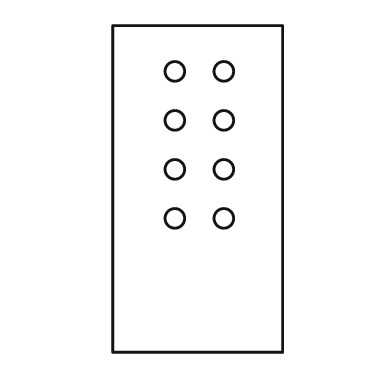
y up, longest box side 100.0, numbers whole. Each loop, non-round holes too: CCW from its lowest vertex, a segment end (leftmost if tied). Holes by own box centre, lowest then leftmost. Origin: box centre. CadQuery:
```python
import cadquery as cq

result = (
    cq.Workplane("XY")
    .moveTo(-26.0, -50.0)
    .lineTo(26.0, -50.0)
    .lineTo(26.0, 50.0)
    .lineTo(-26.0, 50.0)
    .close()
    .moveTo(-7.0, -9.0)
    .circle(3.0)
    .moveTo(8.0, -9.0)
    .circle(3.0)
    .moveTo(-7.0, 6.0)
    .circle(3.0)
    .moveTo(8.0, 6.0)
    .circle(3.0)
    .moveTo(-7.0, 21.0)
    .circle(3.0)
    .moveTo(8.0, 21.0)
    .circle(3.0)
    .moveTo(-7.0, 36.0)
    .circle(3.0)
    .moveTo(8.0, 36.0)
    .circle(3.0)
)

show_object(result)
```